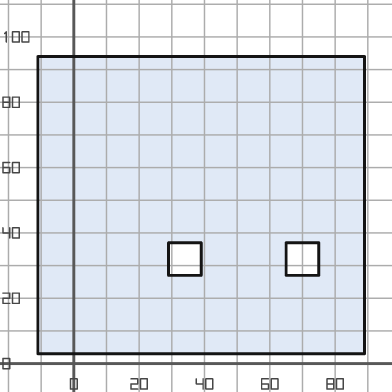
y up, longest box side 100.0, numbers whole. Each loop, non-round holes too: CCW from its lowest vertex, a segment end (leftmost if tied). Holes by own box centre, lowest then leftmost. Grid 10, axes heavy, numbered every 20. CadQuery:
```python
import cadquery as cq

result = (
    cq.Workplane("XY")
    .moveTo(-11.0, 3.0)
    .lineTo(89.0, 3.0)
    .lineTo(89.0, 94.0)
    .lineTo(-11.0, 94.0)
    .close()
    .moveTo(29.0, 27.0)
    .lineTo(39.0, 27.0)
    .lineTo(39.0, 37.0)
    .lineTo(29.0, 37.0)
    .close()
    .moveTo(65.0, 27.0)
    .lineTo(75.0, 27.0)
    .lineTo(75.0, 37.0)
    .lineTo(65.0, 37.0)
    .close()
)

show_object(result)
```